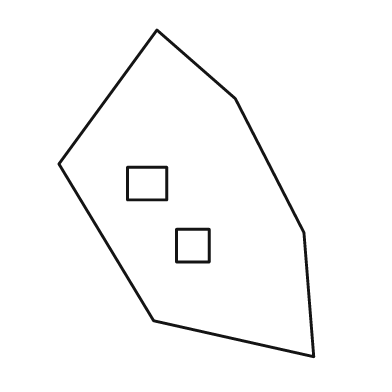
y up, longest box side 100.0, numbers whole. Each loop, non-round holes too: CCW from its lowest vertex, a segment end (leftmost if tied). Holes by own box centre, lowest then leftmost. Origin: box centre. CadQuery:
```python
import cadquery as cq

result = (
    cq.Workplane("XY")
    .moveTo(39.0, -50.0)
    .lineTo(36.0, -12.0)
    .lineTo(15.0, 29.0)
    .lineTo(-9.0, 50.0)
    .lineTo(-39.0, 9.0)
    .lineTo(-10.0, -39.0)
    .close()
    .moveTo(-3.0, -21.0)
    .lineTo(7.0, -21.0)
    .lineTo(7.0, -11.0)
    .lineTo(-3.0, -11.0)
    .close()
    .moveTo(-18.0, -2.0)
    .lineTo(-6.0, -2.0)
    .lineTo(-6.0, 8.0)
    .lineTo(-18.0, 8.0)
    .close()
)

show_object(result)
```